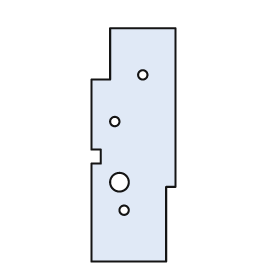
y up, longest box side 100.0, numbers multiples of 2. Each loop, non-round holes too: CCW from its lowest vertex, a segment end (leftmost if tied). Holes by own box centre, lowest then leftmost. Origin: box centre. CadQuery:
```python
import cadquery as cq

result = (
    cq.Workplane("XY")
    .moveTo(-18.0, -50.0)
    .lineTo(14.0, -50.0)
    .lineTo(14.0, -18.0)
    .lineTo(18.0, -18.0)
    .lineTo(18.0, 50.0)
    .lineTo(-10.0, 50.0)
    .lineTo(-10.0, 28.0)
    .lineTo(-18.0, 28.0)
    .lineTo(-18.0, -2.0)
    .lineTo(-14.0, -2.0)
    .lineTo(-14.0, -8.0)
    .lineTo(-18.0, -8.0)
    .close()
    .moveTo(-4.0, -28.0)
    .circle(2.0)
    .moveTo(-6.0, -16.0)
    .circle(4.0)
    .moveTo(-8.0, 10.0)
    .circle(2.0)
    .moveTo(4.0, 30.0)
    .circle(2.0)
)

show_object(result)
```